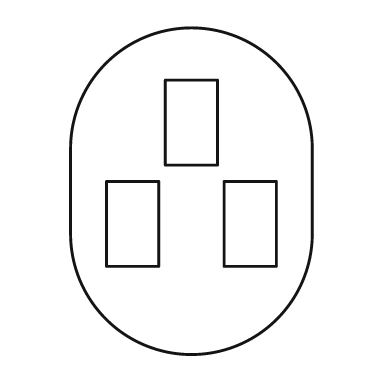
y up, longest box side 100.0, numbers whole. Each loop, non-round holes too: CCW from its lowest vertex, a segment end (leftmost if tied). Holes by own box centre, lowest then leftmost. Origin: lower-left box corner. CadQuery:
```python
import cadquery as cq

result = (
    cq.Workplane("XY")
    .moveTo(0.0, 37.0)
    .threePointArc((37.0, 0.0), (74.0, 37.0))
    .lineTo(74.0, 63.0)
    .threePointArc((37.0, 100.0), (0.0, 63.0))
    .close()
    .moveTo(11.0, 27.0)
    .lineTo(27.0, 27.0)
    .lineTo(27.0, 53.0)
    .lineTo(11.0, 53.0)
    .close()
    .moveTo(47.0, 27.0)
    .lineTo(63.0, 27.0)
    .lineTo(63.0, 53.0)
    .lineTo(47.0, 53.0)
    .close()
    .moveTo(29.0, 58.0)
    .lineTo(45.0, 58.0)
    .lineTo(45.0, 84.0)
    .lineTo(29.0, 84.0)
    .close()
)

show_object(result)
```